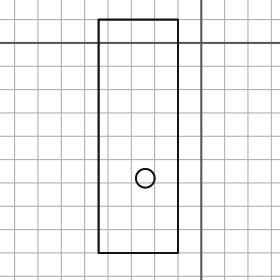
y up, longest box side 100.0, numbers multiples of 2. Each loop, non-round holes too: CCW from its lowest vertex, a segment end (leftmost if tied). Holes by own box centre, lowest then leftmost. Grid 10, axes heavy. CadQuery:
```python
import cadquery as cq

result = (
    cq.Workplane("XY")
    .moveTo(-44.0, -90.0)
    .lineTo(-10.0, -90.0)
    .lineTo(-10.0, 10.0)
    .lineTo(-44.0, 10.0)
    .close()
    .moveTo(-24.0, -58.0)
    .circle(4.0)
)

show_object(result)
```